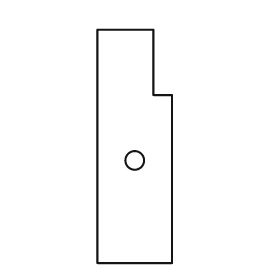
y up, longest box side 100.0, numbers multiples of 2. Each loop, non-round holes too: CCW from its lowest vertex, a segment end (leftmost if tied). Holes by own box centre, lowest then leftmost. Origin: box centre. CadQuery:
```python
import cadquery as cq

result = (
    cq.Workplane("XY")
    .moveTo(-16.0, -50.0)
    .lineTo(16.0, -50.0)
    .lineTo(16.0, 22.0)
    .lineTo(8.0, 22.0)
    .lineTo(8.0, 50.0)
    .lineTo(-16.0, 50.0)
    .close()
    .moveTo(0.0, -6.0)
    .circle(4.0)
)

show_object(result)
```